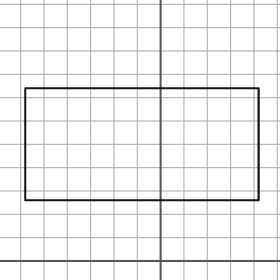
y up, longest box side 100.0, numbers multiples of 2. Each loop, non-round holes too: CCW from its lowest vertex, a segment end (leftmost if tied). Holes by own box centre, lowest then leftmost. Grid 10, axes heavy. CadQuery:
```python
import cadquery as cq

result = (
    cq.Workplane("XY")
    .moveTo(-58.0, 26.0)
    .lineTo(42.0, 26.0)
    .lineTo(42.0, 74.0)
    .lineTo(-58.0, 74.0)
    .close()
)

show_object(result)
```